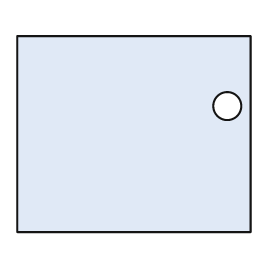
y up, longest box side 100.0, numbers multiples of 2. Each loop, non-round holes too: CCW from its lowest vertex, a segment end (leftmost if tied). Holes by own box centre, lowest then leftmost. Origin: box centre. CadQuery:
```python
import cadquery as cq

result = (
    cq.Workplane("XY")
    .moveTo(-50.0, -42.0)
    .lineTo(50.0, -42.0)
    .lineTo(50.0, 42.0)
    .lineTo(-50.0, 42.0)
    .close()
    .moveTo(40.0, 12.0)
    .circle(6.0)
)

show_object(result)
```